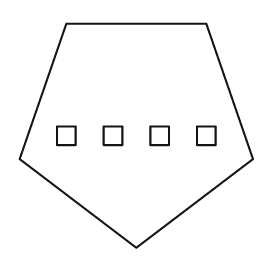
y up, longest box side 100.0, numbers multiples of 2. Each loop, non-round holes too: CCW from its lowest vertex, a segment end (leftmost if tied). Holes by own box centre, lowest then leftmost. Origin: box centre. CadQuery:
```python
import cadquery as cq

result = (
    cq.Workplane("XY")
    .moveTo(0.0, -48.0)
    .lineTo(50.0, -10.0)
    .lineTo(30.0, 48.0)
    .lineTo(-30.0, 48.0)
    .lineTo(-50.0, -10.0)
    .close()
    .moveTo(-34.0, -4.0)
    .lineTo(-26.0, -4.0)
    .lineTo(-26.0, 4.0)
    .lineTo(-34.0, 4.0)
    .close()
    .moveTo(-14.0, -4.0)
    .lineTo(-6.0, -4.0)
    .lineTo(-6.0, 4.0)
    .lineTo(-14.0, 4.0)
    .close()
    .moveTo(6.0, -4.0)
    .lineTo(14.0, -4.0)
    .lineTo(14.0, 4.0)
    .lineTo(6.0, 4.0)
    .close()
    .moveTo(26.0, -4.0)
    .lineTo(34.0, -4.0)
    .lineTo(34.0, 4.0)
    .lineTo(26.0, 4.0)
    .close()
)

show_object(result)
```